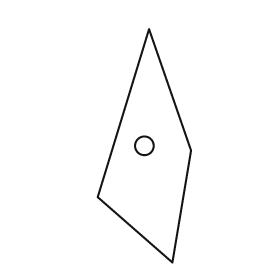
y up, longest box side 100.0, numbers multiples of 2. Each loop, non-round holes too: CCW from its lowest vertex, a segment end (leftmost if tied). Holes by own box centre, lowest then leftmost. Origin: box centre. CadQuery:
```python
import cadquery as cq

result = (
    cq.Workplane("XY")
    .moveTo(12.0, -50.0)
    .lineTo(20.0, -2.0)
    .lineTo(2.0, 50.0)
    .lineTo(-20.0, -22.0)
    .close()
    .moveTo(0.0, 0.0)
    .circle(4.0)
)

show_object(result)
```